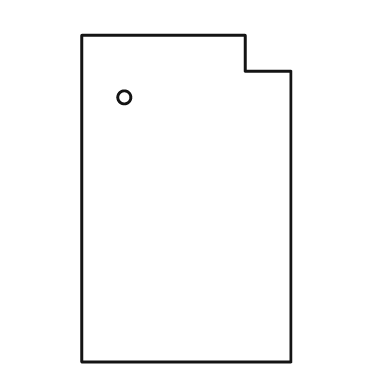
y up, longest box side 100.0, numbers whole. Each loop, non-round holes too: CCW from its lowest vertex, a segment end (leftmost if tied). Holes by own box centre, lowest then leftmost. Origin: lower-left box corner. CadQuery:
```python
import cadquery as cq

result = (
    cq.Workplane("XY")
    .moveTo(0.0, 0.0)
    .lineTo(64.0, 0.0)
    .lineTo(64.0, 89.0)
    .lineTo(50.0, 89.0)
    .lineTo(50.0, 100.0)
    .lineTo(0.0, 100.0)
    .close()
    .moveTo(13.0, 81.0)
    .circle(2.0)
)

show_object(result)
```